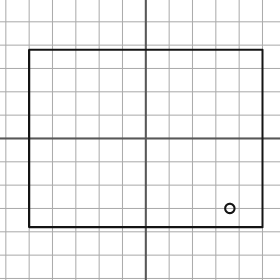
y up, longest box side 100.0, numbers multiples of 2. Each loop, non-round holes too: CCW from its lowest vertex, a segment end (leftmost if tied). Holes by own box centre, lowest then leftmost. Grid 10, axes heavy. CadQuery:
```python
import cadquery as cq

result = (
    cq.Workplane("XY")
    .moveTo(-50.0, -38.0)
    .lineTo(50.0, -38.0)
    .lineTo(50.0, 38.0)
    .lineTo(-50.0, 38.0)
    .close()
    .moveTo(36.0, -30.0)
    .circle(2.0)
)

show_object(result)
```